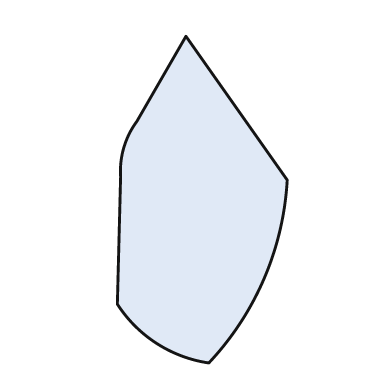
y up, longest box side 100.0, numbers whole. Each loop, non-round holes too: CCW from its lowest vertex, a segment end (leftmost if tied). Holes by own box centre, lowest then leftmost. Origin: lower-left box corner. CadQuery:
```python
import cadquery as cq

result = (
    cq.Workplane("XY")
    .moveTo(28.0, 0.0)
    .threePointArc((45.0, 26.0), (52.0, 56.0))
    .lineTo(21.0, 100.0)
    .lineTo(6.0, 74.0)
    .threePointArc((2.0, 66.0), (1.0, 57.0))
    .lineTo(0.0, 18.0)
    .threePointArc((12.0, 6.0), (28.0, 0.0))
    .close()
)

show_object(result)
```